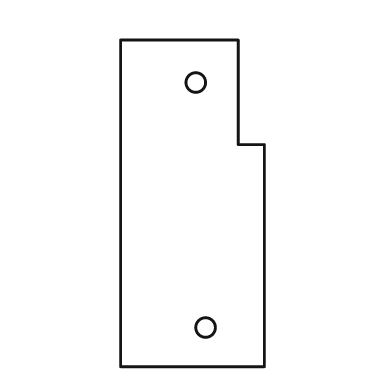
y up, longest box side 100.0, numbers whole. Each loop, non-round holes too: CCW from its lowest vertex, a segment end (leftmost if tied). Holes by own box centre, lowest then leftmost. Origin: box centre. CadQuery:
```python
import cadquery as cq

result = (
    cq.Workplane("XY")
    .moveTo(-22.0, -50.0)
    .lineTo(22.0, -50.0)
    .lineTo(22.0, 18.0)
    .lineTo(14.0, 18.0)
    .lineTo(14.0, 50.0)
    .lineTo(-22.0, 50.0)
    .close()
    .moveTo(4.0, -38.0)
    .circle(3.0)
    .moveTo(1.0, 37.0)
    .circle(3.0)
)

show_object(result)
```